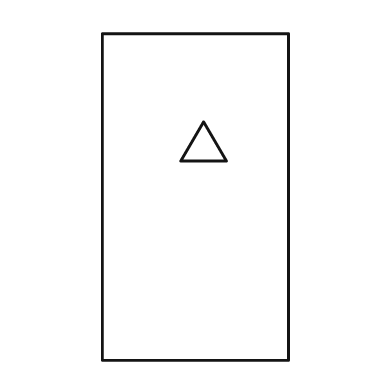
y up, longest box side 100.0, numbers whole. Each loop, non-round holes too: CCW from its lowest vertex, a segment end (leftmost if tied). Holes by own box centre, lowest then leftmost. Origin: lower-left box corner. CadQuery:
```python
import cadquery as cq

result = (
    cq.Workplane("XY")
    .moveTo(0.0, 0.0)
    .lineTo(57.0, 0.0)
    .lineTo(57.0, 100.0)
    .lineTo(0.0, 100.0)
    .close()
    .moveTo(24.0, 61.0)
    .lineTo(38.0, 61.0)
    .lineTo(31.0, 73.0)
    .close()
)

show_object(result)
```